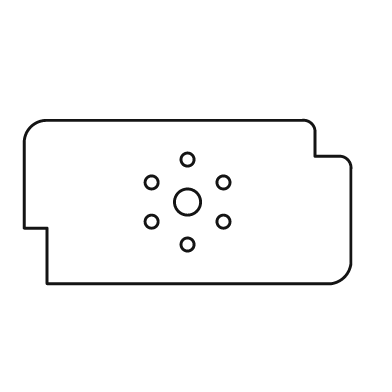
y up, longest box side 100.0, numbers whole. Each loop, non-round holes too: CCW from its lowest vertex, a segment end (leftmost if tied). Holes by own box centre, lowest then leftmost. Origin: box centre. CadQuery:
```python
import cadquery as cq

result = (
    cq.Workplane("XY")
    .moveTo(-43.0, -25.0)
    .lineTo(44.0, -25.0)
    .threePointArc((48.0, -23.0), (50.0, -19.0))
    .lineTo(50.0, 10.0)
    .threePointArc((49.0, 13.0), (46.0, 14.0))
    .lineTo(39.0, 14.0)
    .lineTo(39.0, 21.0)
    .threePointArc((38.0, 24.0), (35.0, 25.0))
    .lineTo(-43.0, 25.0)
    .threePointArc((-48.0, 23.0), (-50.0, 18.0))
    .lineTo(-50.0, -8.0)
    .lineTo(-43.0, -8.0)
    .close()
    .moveTo(0.0, -13.0)
    .circle(2.0)
    .moveTo(-11.0, -6.0)
    .circle(2.0)
    .moveTo(11.0, -6.0)
    .circle(2.0)
    .moveTo(0.0, 0.0)
    .circle(4.0)
    .moveTo(-11.0, 6.0)
    .circle(2.0)
    .moveTo(11.0, 6.0)
    .circle(2.0)
    .moveTo(0.0, 13.0)
    .circle(2.0)
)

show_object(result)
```